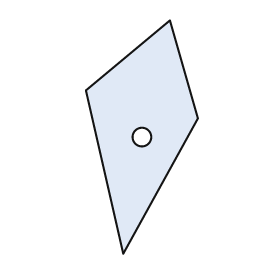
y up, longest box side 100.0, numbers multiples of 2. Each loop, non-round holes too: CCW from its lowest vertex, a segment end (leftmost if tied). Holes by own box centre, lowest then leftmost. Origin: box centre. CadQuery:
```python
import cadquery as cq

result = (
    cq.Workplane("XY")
    .moveTo(-8.0, -50.0)
    .lineTo(24.0, 8.0)
    .lineTo(12.0, 50.0)
    .lineTo(-24.0, 20.0)
    .close()
    .moveTo(0.0, 0.0)
    .circle(4.0)
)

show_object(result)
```